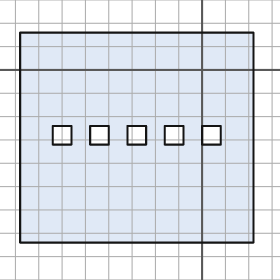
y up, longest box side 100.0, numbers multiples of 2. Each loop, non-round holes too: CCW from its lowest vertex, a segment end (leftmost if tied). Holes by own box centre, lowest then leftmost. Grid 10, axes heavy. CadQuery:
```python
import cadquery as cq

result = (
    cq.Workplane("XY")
    .moveTo(-78.0, -74.0)
    .lineTo(22.0, -74.0)
    .lineTo(22.0, 16.0)
    .lineTo(-78.0, 16.0)
    .close()
    .moveTo(-64.0, -32.0)
    .lineTo(-56.0, -32.0)
    .lineTo(-56.0, -24.0)
    .lineTo(-64.0, -24.0)
    .close()
    .moveTo(-48.0, -32.0)
    .lineTo(-40.0, -32.0)
    .lineTo(-40.0, -24.0)
    .lineTo(-48.0, -24.0)
    .close()
    .moveTo(-32.0, -32.0)
    .lineTo(-24.0, -32.0)
    .lineTo(-24.0, -24.0)
    .lineTo(-32.0, -24.0)
    .close()
    .moveTo(-16.0, -32.0)
    .lineTo(-8.0, -32.0)
    .lineTo(-8.0, -24.0)
    .lineTo(-16.0, -24.0)
    .close()
    .moveTo(0.0, -32.0)
    .lineTo(8.0, -32.0)
    .lineTo(8.0, -24.0)
    .lineTo(0.0, -24.0)
    .close()
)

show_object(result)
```